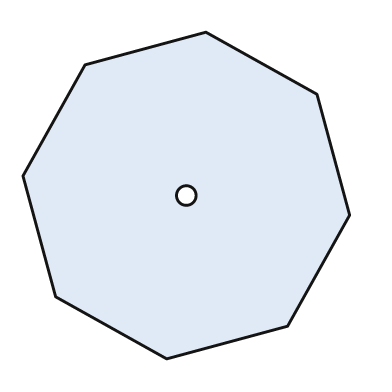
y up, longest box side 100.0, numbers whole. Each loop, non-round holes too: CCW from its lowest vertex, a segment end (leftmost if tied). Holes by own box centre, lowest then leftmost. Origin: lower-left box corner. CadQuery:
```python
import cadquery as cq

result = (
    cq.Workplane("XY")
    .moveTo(44.0, 0.0)
    .lineTo(81.0, 10.0)
    .lineTo(100.0, 44.0)
    .lineTo(90.0, 81.0)
    .lineTo(56.0, 100.0)
    .lineTo(19.0, 90.0)
    .lineTo(0.0, 56.0)
    .lineTo(10.0, 19.0)
    .close()
    .moveTo(50.0, 50.0)
    .circle(3.0)
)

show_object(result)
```